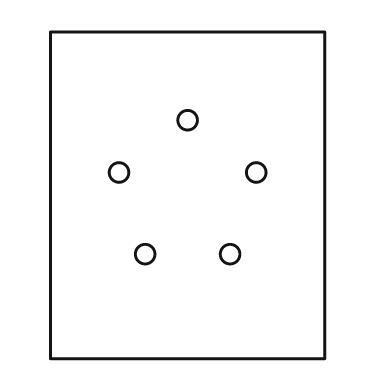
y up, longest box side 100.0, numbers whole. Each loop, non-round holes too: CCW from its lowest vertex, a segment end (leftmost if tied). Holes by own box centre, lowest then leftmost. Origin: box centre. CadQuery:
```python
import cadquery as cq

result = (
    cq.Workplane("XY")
    .moveTo(-42.0, -50.0)
    .lineTo(42.0, -50.0)
    .lineTo(42.0, 50.0)
    .lineTo(-42.0, 50.0)
    .close()
    .moveTo(-13.0, -18.0)
    .circle(3.0)
    .moveTo(13.0, -18.0)
    .circle(3.0)
    .moveTo(-21.0, 7.0)
    .circle(3.0)
    .moveTo(21.0, 7.0)
    .circle(3.0)
    .moveTo(0.0, 23.0)
    .circle(3.0)
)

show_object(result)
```